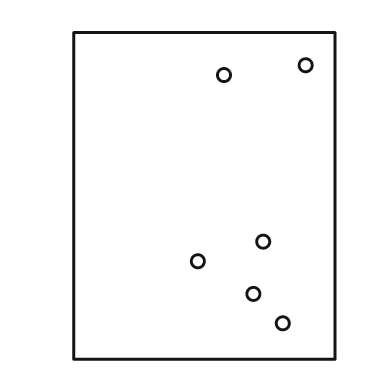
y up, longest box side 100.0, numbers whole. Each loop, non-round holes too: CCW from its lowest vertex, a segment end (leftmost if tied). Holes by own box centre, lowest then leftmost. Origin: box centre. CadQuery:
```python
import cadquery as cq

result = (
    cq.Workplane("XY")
    .moveTo(-40.0, -50.0)
    .lineTo(40.0, -50.0)
    .lineTo(40.0, 50.0)
    .lineTo(-40.0, 50.0)
    .close()
    .moveTo(24.0, -39.0)
    .circle(2.0)
    .moveTo(15.0, -30.0)
    .circle(2.0)
    .moveTo(-2.0, -20.0)
    .circle(2.0)
    .moveTo(18.0, -14.0)
    .circle(2.0)
    .moveTo(6.0, 37.0)
    .circle(2.0)
    .moveTo(31.0, 40.0)
    .circle(2.0)
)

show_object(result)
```